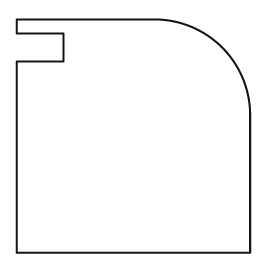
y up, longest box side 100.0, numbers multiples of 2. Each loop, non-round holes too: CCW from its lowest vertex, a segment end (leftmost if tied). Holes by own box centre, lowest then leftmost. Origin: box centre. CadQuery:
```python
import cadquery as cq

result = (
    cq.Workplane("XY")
    .moveTo(-50.0, -50.0)
    .lineTo(50.0, -50.0)
    .lineTo(50.0, 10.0)
    .threePointArc((38.0, 38.0), (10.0, 50.0))
    .lineTo(-50.0, 50.0)
    .lineTo(-50.0, 44.0)
    .lineTo(-30.0, 44.0)
    .lineTo(-30.0, 32.0)
    .lineTo(-50.0, 32.0)
    .close()
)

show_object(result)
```